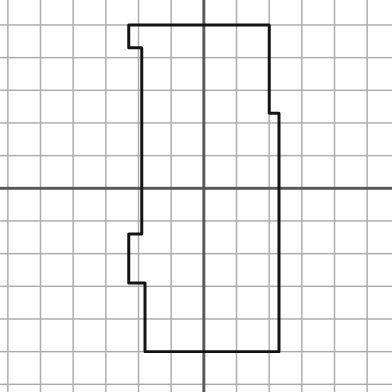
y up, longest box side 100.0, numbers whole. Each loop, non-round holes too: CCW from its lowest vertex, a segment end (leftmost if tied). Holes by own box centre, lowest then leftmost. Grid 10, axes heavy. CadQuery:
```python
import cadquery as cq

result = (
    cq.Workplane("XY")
    .moveTo(-18.0, -50.0)
    .lineTo(23.0, -50.0)
    .lineTo(23.0, 23.0)
    .lineTo(20.0, 23.0)
    .lineTo(20.0, 50.0)
    .lineTo(-23.0, 50.0)
    .lineTo(-23.0, 43.0)
    .lineTo(-19.0, 43.0)
    .lineTo(-19.0, -14.0)
    .lineTo(-23.0, -14.0)
    .lineTo(-23.0, -29.0)
    .lineTo(-18.0, -29.0)
    .close()
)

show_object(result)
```